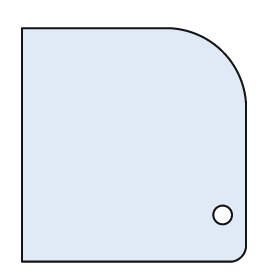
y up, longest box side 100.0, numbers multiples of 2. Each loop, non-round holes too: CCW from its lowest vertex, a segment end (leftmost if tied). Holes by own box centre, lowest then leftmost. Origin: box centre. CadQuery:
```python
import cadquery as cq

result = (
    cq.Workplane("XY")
    .moveTo(-48.0, -50.0)
    .lineTo(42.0, -50.0)
    .threePointArc((46.0, -48.0), (48.0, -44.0))
    .lineTo(48.0, 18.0)
    .threePointArc((38.0, 40.0), (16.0, 50.0))
    .lineTo(-48.0, 50.0)
    .close()
    .moveTo(38.0, -30.0)
    .circle(4.0)
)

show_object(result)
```